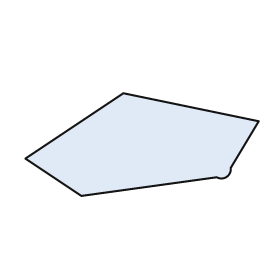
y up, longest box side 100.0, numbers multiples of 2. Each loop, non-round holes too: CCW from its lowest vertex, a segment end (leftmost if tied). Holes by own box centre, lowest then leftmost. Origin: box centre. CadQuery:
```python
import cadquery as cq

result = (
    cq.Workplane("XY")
    .moveTo(-26.0, -22.0)
    .lineTo(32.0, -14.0)
    .threePointArc((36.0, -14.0), (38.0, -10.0))
    .lineTo(50.0, 10.0)
    .lineTo(-8.0, 22.0)
    .lineTo(-50.0, -6.0)
    .close()
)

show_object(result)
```